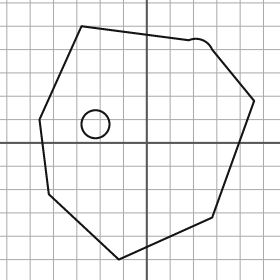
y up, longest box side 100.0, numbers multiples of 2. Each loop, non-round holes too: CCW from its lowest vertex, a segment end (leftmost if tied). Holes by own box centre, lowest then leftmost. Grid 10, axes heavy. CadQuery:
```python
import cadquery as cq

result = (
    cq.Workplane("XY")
    .moveTo(-12.0, -50.0)
    .lineTo(28.0, -32.0)
    .lineTo(46.0, 18.0)
    .lineTo(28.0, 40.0)
    .threePointArc((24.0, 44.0), (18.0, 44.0))
    .lineTo(-28.0, 50.0)
    .lineTo(-46.0, 10.0)
    .lineTo(-42.0, -22.0)
    .close()
    .moveTo(-22.0, 8.0)
    .circle(6.0)
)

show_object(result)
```